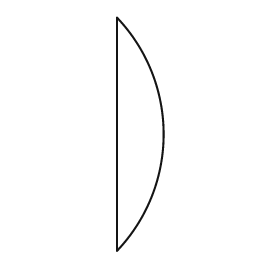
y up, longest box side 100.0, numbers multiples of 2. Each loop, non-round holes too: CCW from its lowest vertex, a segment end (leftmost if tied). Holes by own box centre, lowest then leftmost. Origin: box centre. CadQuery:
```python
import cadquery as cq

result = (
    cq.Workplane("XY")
    .moveTo(-10.0, -50.0)
    .threePointArc((10.0, 0.0), (-10.0, 50.0))
    .close()
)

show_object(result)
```